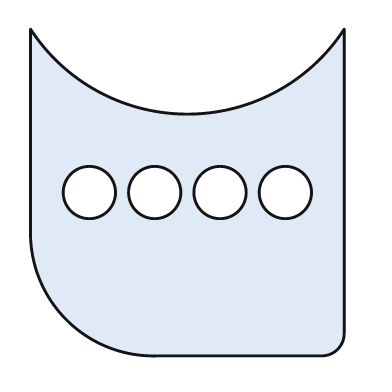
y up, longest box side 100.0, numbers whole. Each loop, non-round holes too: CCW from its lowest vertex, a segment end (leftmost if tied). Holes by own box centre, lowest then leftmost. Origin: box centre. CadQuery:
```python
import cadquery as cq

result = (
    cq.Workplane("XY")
    .moveTo(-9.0, -50.0)
    .lineTo(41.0, -50.0)
    .threePointArc((46.0, -48.0), (48.0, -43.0))
    .lineTo(48.0, 50.0)
    .threePointArc((0.0, 24.0), (-48.0, 50.0))
    .lineTo(-48.0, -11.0)
    .threePointArc((-37.0, -39.0), (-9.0, -50.0))
    .close()
    .moveTo(-30.0, 0.0)
    .circle(8.0)
    .moveTo(-10.0, 0.0)
    .circle(8.0)
    .moveTo(10.0, 0.0)
    .circle(8.0)
    .moveTo(30.0, 0.0)
    .circle(8.0)
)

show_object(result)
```